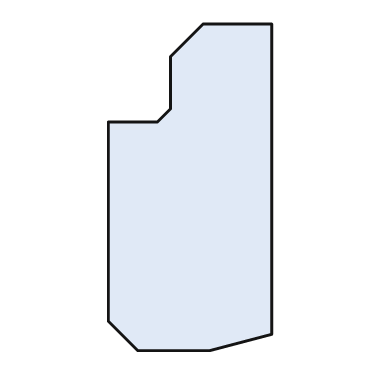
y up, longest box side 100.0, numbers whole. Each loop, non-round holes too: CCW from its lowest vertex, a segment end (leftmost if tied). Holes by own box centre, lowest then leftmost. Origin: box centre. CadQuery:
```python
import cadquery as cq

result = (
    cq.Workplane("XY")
    .moveTo(-16.0, -50.0)
    .lineTo(6.0, -50.0)
    .lineTo(25.0, -45.0)
    .lineTo(25.0, 50.0)
    .lineTo(4.0, 50.0)
    .lineTo(-6.0, 40.0)
    .lineTo(-6.0, 24.0)
    .lineTo(-10.0, 20.0)
    .lineTo(-25.0, 20.0)
    .lineTo(-25.0, -41.0)
    .close()
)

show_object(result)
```